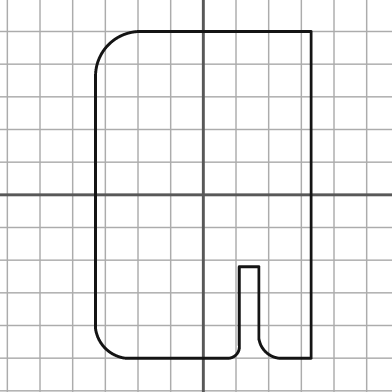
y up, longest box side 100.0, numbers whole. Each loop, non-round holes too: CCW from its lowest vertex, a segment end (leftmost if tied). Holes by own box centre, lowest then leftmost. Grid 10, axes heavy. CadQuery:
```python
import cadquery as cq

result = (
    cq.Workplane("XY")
    .moveTo(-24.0, -50.0)
    .lineTo(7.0, -50.0)
    .threePointArc((10.0, -49.0), (11.0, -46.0))
    .lineTo(11.0, -22.0)
    .lineTo(17.0, -22.0)
    .lineTo(17.0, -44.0)
    .threePointArc((19.0, -48.0), (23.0, -50.0))
    .lineTo(33.0, -50.0)
    .lineTo(33.0, 50.0)
    .lineTo(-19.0, 50.0)
    .threePointArc((-29.0, 46.0), (-33.0, 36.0))
    .lineTo(-33.0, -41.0)
    .threePointArc((-30.0, -47.0), (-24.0, -50.0))
    .close()
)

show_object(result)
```